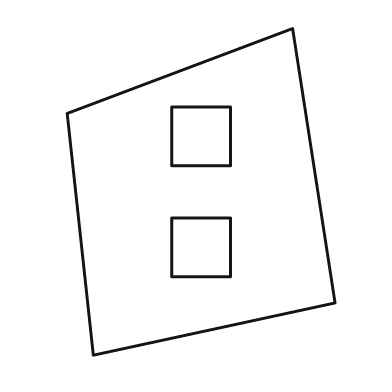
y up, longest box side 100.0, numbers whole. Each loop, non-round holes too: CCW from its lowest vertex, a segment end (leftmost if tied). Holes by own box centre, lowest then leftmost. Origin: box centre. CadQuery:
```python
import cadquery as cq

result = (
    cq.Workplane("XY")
    .moveTo(-33.0, -50.0)
    .lineTo(41.0, -34.0)
    .lineTo(28.0, 50.0)
    .lineTo(-41.0, 24.0)
    .close()
    .moveTo(-9.0, -26.0)
    .lineTo(9.0, -26.0)
    .lineTo(9.0, -8.0)
    .lineTo(-9.0, -8.0)
    .close()
    .moveTo(-9.0, 8.0)
    .lineTo(9.0, 8.0)
    .lineTo(9.0, 26.0)
    .lineTo(-9.0, 26.0)
    .close()
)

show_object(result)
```